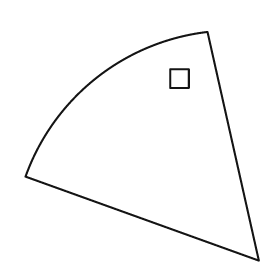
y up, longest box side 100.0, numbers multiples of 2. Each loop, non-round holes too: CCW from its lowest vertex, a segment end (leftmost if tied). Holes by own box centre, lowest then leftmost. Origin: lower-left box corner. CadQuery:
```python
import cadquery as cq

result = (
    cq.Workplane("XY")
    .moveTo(100.0, 0.0)
    .lineTo(78.0, 98.0)
    .threePointArc((30.0, 78.0), (0.0, 36.0))
    .close()
    .moveTo(62.0, 74.0)
    .lineTo(70.0, 74.0)
    .lineTo(70.0, 82.0)
    .lineTo(62.0, 82.0)
    .close()
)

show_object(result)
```